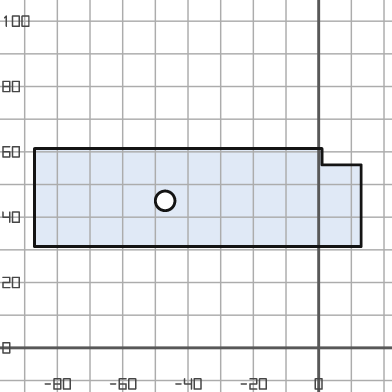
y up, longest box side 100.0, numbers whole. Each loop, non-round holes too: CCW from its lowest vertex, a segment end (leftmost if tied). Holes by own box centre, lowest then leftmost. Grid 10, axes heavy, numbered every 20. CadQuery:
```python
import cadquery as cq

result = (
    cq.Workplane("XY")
    .moveTo(-87.0, 31.0)
    .lineTo(13.0, 31.0)
    .lineTo(13.0, 56.0)
    .lineTo(1.0, 56.0)
    .lineTo(1.0, 61.0)
    .lineTo(-87.0, 61.0)
    .close()
    .moveTo(-47.0, 45.0)
    .circle(3.0)
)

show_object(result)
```